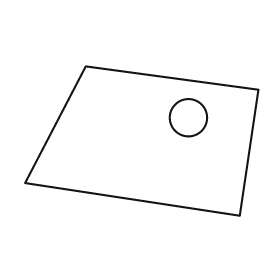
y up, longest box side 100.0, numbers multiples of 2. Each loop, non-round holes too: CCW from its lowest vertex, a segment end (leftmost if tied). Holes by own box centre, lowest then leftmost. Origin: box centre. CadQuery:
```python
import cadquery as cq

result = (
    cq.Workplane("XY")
    .moveTo(42.0, -32.0)
    .lineTo(50.0, 22.0)
    .lineTo(-24.0, 32.0)
    .lineTo(-50.0, -18.0)
    .close()
    .moveTo(20.0, 10.0)
    .circle(8.0)
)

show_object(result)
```